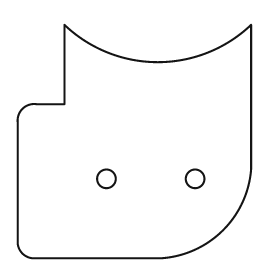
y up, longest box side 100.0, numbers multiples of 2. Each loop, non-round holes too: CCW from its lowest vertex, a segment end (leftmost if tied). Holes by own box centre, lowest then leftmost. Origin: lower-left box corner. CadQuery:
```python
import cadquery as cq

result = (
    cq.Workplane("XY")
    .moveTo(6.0, 0.0)
    .lineTo(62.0, 0.0)
    .threePointArc((88.0, 12.0), (100.0, 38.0))
    .lineTo(100.0, 100.0)
    .threePointArc((60.0, 84.0), (20.0, 100.0))
    .lineTo(20.0, 66.0)
    .lineTo(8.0, 66.0)
    .threePointArc((2.0, 64.0), (0.0, 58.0))
    .lineTo(0.0, 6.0)
    .threePointArc((2.0, 2.0), (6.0, 0.0))
    .close()
    .moveTo(38.0, 34.0)
    .circle(4.0)
    .moveTo(76.0, 34.0)
    .circle(4.0)
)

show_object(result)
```